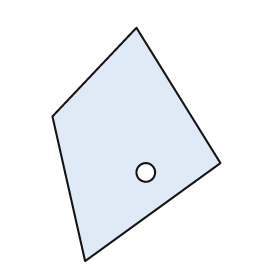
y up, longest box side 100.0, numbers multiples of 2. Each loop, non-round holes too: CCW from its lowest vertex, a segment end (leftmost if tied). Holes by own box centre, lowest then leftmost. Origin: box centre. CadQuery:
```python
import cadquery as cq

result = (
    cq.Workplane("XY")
    .moveTo(-22.0, -50.0)
    .lineTo(36.0, -8.0)
    .lineTo(0.0, 50.0)
    .lineTo(-36.0, 12.0)
    .close()
    .moveTo(4.0, -12.0)
    .circle(4.0)
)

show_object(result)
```